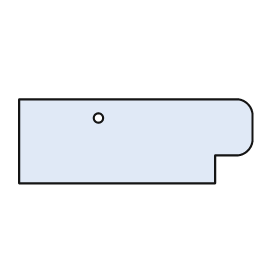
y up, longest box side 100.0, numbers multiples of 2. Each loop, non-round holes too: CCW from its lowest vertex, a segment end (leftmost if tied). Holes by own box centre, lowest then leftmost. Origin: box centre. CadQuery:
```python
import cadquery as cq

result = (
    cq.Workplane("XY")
    .moveTo(-50.0, -18.0)
    .lineTo(34.0, -18.0)
    .lineTo(34.0, -6.0)
    .lineTo(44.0, -6.0)
    .threePointArc((48.0, -4.0), (50.0, 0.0))
    .lineTo(50.0, 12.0)
    .threePointArc((48.0, 16.0), (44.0, 18.0))
    .lineTo(-50.0, 18.0)
    .close()
    .moveTo(-16.0, 10.0)
    .circle(2.0)
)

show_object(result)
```